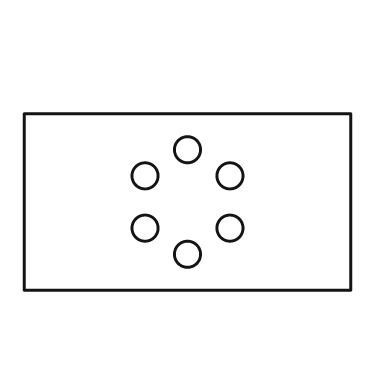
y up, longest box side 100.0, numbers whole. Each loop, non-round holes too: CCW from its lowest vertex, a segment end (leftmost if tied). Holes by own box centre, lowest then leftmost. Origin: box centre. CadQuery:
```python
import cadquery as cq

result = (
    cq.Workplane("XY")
    .moveTo(-50.0, -27.0)
    .lineTo(50.0, -27.0)
    .lineTo(50.0, 27.0)
    .lineTo(-50.0, 27.0)
    .close()
    .moveTo(0.0, -16.0)
    .circle(4.0)
    .moveTo(-13.0, -8.0)
    .circle(4.0)
    .moveTo(13.0, -8.0)
    .circle(4.0)
    .moveTo(-13.0, 8.0)
    .circle(4.0)
    .moveTo(13.0, 8.0)
    .circle(4.0)
    .moveTo(0.0, 16.0)
    .circle(4.0)
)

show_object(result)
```